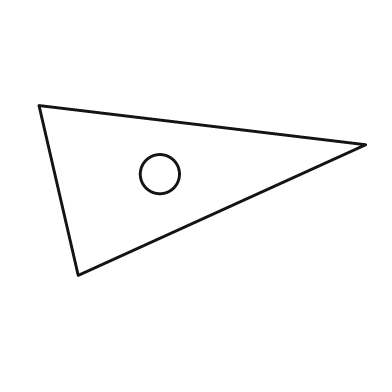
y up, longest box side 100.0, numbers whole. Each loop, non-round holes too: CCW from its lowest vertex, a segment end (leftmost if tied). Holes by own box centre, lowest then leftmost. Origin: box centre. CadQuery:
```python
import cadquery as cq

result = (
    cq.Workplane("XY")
    .moveTo(-38.0, -26.0)
    .lineTo(50.0, 14.0)
    .lineTo(-50.0, 26.0)
    .close()
    .moveTo(-13.0, 5.0)
    .circle(6.0)
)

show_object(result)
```